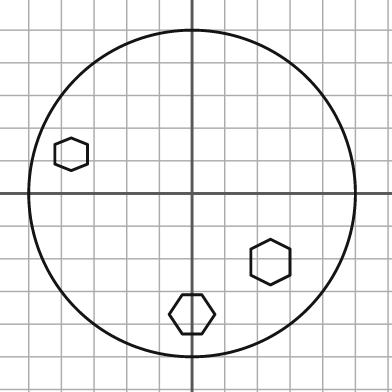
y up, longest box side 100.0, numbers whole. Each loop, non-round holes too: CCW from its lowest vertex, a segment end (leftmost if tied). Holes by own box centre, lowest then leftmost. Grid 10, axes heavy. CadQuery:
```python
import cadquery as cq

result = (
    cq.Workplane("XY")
    .moveTo(0.0, 0.0)
    .circle(50.0)
    .moveTo(-3.0, -43.0)
    .lineTo(3.0, -43.0)
    .lineTo(7.0, -37.0)
    .lineTo(3.0, -31.0)
    .lineTo(-3.0, -31.0)
    .lineTo(-7.0, -37.0)
    .close()
    .moveTo(24.0, -28.0)
    .lineTo(30.0, -25.0)
    .lineTo(30.0, -17.0)
    .lineTo(24.0, -14.0)
    .lineTo(18.0, -17.0)
    .lineTo(18.0, -25.0)
    .close()
    .moveTo(-37.0, 7.0)
    .lineTo(-32.0, 9.0)
    .lineTo(-32.0, 15.0)
    .lineTo(-37.0, 17.0)
    .lineTo(-42.0, 15.0)
    .lineTo(-42.0, 9.0)
    .close()
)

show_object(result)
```